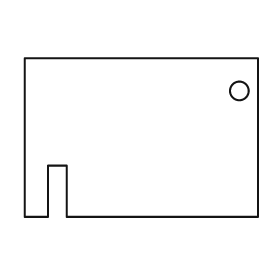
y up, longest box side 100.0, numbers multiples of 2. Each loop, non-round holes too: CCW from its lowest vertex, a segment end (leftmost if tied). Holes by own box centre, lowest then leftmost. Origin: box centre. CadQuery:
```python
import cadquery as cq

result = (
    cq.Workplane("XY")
    .moveTo(-50.0, -34.0)
    .lineTo(-40.0, -34.0)
    .lineTo(-40.0, -12.0)
    .lineTo(-32.0, -12.0)
    .lineTo(-32.0, -34.0)
    .lineTo(50.0, -34.0)
    .lineTo(50.0, 34.0)
    .lineTo(-50.0, 34.0)
    .close()
    .moveTo(42.0, 20.0)
    .circle(4.0)
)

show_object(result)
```